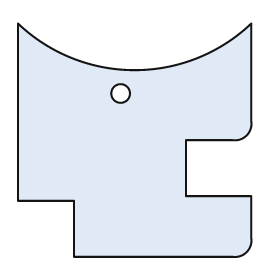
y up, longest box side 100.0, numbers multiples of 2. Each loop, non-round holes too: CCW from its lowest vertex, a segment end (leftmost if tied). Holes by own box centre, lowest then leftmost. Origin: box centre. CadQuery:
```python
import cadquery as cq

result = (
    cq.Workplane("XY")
    .moveTo(-26.0, -50.0)
    .lineTo(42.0, -50.0)
    .threePointArc((48.0, -48.0), (50.0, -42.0))
    .lineTo(50.0, -24.0)
    .lineTo(22.0, -24.0)
    .lineTo(22.0, 0.0)
    .lineTo(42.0, 0.0)
    .threePointArc((48.0, 2.0), (50.0, 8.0))
    .lineTo(50.0, 50.0)
    .threePointArc((0.0, 30.0), (-50.0, 50.0))
    .lineTo(-50.0, -26.0)
    .lineTo(-26.0, -26.0)
    .close()
    .moveTo(-6.0, 20.0)
    .circle(4.0)
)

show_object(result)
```